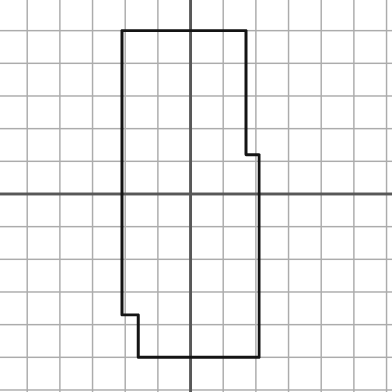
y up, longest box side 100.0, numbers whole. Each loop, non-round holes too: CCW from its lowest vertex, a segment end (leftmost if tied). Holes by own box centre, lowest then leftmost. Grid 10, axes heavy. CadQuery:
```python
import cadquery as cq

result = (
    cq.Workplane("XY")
    .moveTo(-16.0, -50.0)
    .lineTo(21.0, -50.0)
    .lineTo(21.0, 12.0)
    .lineTo(17.0, 12.0)
    .lineTo(17.0, 50.0)
    .lineTo(-21.0, 50.0)
    .lineTo(-21.0, -37.0)
    .lineTo(-16.0, -37.0)
    .close()
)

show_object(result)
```